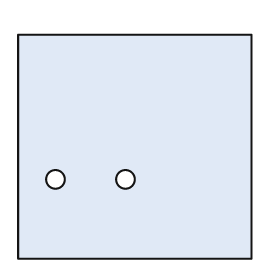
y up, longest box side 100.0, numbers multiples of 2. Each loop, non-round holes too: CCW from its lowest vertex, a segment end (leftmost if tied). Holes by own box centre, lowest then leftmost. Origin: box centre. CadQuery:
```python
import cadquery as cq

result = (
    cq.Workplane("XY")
    .moveTo(-50.0, -48.0)
    .lineTo(50.0, -48.0)
    .lineTo(50.0, 48.0)
    .lineTo(-50.0, 48.0)
    .close()
    .moveTo(-34.0, -14.0)
    .circle(4.0)
    .moveTo(-4.0, -14.0)
    .circle(4.0)
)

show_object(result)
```